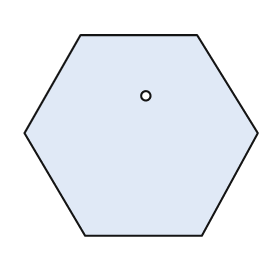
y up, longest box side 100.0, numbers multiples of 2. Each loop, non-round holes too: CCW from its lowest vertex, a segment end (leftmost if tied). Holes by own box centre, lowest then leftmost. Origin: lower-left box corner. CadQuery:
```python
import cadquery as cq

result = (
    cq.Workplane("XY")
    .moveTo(26.0, 0.0)
    .lineTo(76.0, 0.0)
    .lineTo(100.0, 44.0)
    .lineTo(74.0, 86.0)
    .lineTo(24.0, 86.0)
    .lineTo(0.0, 44.0)
    .close()
    .moveTo(52.0, 60.0)
    .circle(2.0)
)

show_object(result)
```